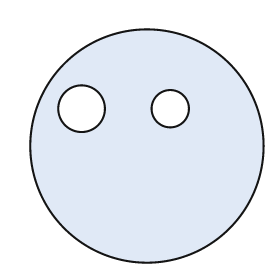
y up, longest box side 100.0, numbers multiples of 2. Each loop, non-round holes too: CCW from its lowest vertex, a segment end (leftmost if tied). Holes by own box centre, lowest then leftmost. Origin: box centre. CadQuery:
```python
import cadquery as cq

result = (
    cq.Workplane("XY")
    .moveTo(0.0, 0.0)
    .circle(50.0)
    .moveTo(-28.0, 16.0)
    .circle(10.0)
    .moveTo(10.0, 16.0)
    .circle(8.0)
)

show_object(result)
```